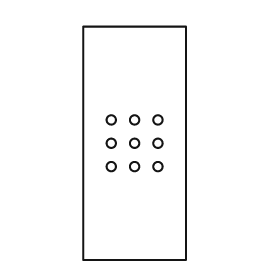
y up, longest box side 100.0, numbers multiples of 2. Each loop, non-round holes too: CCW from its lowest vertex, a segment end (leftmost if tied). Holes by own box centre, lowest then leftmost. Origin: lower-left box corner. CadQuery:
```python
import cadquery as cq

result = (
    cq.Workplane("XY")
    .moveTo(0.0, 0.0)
    .lineTo(44.0, 0.0)
    .lineTo(44.0, 100.0)
    .lineTo(0.0, 100.0)
    .close()
    .moveTo(12.0, 40.0)
    .circle(2.0)
    .moveTo(22.0, 40.0)
    .circle(2.0)
    .moveTo(32.0, 40.0)
    .circle(2.0)
    .moveTo(12.0, 50.0)
    .circle(2.0)
    .moveTo(22.0, 50.0)
    .circle(2.0)
    .moveTo(32.0, 50.0)
    .circle(2.0)
    .moveTo(12.0, 60.0)
    .circle(2.0)
    .moveTo(22.0, 60.0)
    .circle(2.0)
    .moveTo(32.0, 60.0)
    .circle(2.0)
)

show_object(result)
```